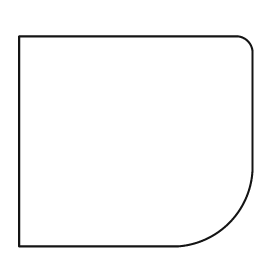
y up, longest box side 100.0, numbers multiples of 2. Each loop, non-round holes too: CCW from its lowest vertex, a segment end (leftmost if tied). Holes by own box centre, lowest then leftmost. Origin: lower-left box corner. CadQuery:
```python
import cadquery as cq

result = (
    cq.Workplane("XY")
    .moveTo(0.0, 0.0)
    .lineTo(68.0, 0.0)
    .threePointArc((90.0, 10.0), (100.0, 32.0))
    .lineTo(100.0, 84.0)
    .threePointArc((98.0, 88.0), (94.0, 90.0))
    .lineTo(0.0, 90.0)
    .close()
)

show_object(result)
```